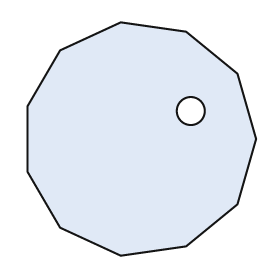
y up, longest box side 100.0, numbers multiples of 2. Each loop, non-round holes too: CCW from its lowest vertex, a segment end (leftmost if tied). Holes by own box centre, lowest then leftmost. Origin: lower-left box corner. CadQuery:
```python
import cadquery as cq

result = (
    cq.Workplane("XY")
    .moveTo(40.0, 0.0)
    .lineTo(68.0, 4.0)
    .lineTo(90.0, 22.0)
    .lineTo(98.0, 50.0)
    .lineTo(90.0, 78.0)
    .lineTo(68.0, 96.0)
    .lineTo(40.0, 100.0)
    .lineTo(14.0, 88.0)
    .lineTo(0.0, 64.0)
    .lineTo(0.0, 36.0)
    .lineTo(14.0, 12.0)
    .close()
    .moveTo(70.0, 62.0)
    .circle(6.0)
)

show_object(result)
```